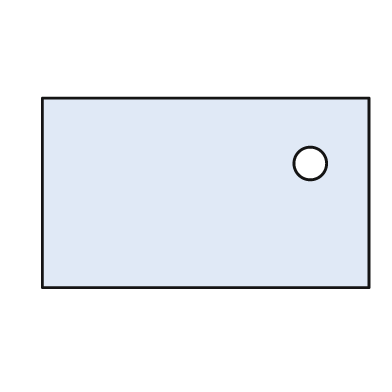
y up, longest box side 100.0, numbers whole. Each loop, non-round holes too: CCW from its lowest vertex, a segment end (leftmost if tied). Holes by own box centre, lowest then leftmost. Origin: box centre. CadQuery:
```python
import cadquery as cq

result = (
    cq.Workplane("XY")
    .moveTo(-50.0, -29.0)
    .lineTo(50.0, -29.0)
    .lineTo(50.0, 29.0)
    .lineTo(-50.0, 29.0)
    .close()
    .moveTo(32.0, 9.0)
    .circle(5.0)
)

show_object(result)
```